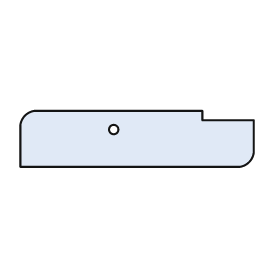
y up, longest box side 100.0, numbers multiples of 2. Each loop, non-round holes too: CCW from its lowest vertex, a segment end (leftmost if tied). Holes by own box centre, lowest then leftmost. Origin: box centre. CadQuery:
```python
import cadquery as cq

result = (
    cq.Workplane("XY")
    .moveTo(-50.0, -12.0)
    .lineTo(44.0, -12.0)
    .threePointArc((48.0, -10.0), (50.0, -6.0))
    .lineTo(50.0, 8.0)
    .lineTo(28.0, 8.0)
    .lineTo(28.0, 12.0)
    .lineTo(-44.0, 12.0)
    .threePointArc((-48.0, 10.0), (-50.0, 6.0))
    .close()
    .moveTo(-10.0, 4.0)
    .circle(2.0)
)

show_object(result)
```